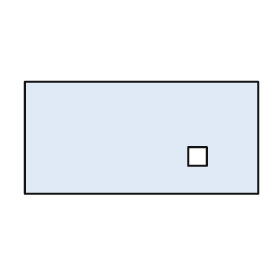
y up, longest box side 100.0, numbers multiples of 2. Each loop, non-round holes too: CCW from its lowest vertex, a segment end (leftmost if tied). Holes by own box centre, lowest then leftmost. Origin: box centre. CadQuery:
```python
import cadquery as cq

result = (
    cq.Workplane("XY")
    .moveTo(-50.0, -24.0)
    .lineTo(50.0, -24.0)
    .lineTo(50.0, 24.0)
    .lineTo(-50.0, 24.0)
    .close()
    .moveTo(20.0, -12.0)
    .lineTo(28.0, -12.0)
    .lineTo(28.0, -4.0)
    .lineTo(20.0, -4.0)
    .close()
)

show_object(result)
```